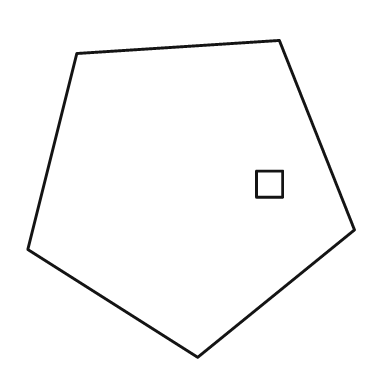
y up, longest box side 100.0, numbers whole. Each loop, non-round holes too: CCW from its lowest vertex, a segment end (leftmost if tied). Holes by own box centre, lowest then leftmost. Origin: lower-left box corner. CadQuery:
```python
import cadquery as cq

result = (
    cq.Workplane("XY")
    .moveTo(52.0, 0.0)
    .lineTo(100.0, 39.0)
    .lineTo(77.0, 97.0)
    .lineTo(15.0, 93.0)
    .lineTo(0.0, 33.0)
    .close()
    .moveTo(70.0, 49.0)
    .lineTo(78.0, 49.0)
    .lineTo(78.0, 57.0)
    .lineTo(70.0, 57.0)
    .close()
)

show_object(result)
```